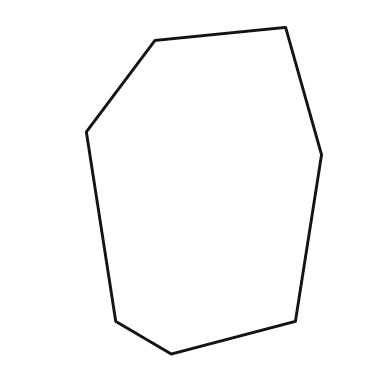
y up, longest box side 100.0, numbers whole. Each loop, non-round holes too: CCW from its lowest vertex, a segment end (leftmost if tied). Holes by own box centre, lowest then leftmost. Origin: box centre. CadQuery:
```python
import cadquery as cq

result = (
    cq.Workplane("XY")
    .moveTo(-10.0, -50.0)
    .lineTo(28.0, -40.0)
    .lineTo(36.0, 11.0)
    .lineTo(25.0, 50.0)
    .lineTo(-15.0, 46.0)
    .lineTo(-36.0, 18.0)
    .lineTo(-27.0, -40.0)
    .close()
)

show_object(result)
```